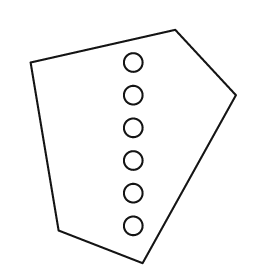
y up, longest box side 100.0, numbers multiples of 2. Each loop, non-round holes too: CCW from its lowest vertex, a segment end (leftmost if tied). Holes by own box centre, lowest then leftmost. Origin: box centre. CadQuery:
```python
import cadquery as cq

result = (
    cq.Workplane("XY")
    .moveTo(4.0, -50.0)
    .lineTo(44.0, 22.0)
    .lineTo(18.0, 50.0)
    .lineTo(-44.0, 36.0)
    .lineTo(-32.0, -36.0)
    .close()
    .moveTo(0.0, -34.0)
    .circle(4.0)
    .moveTo(0.0, -20.0)
    .circle(4.0)
    .moveTo(0.0, -6.0)
    .circle(4.0)
    .moveTo(0.0, 8.0)
    .circle(4.0)
    .moveTo(0.0, 22.0)
    .circle(4.0)
    .moveTo(0.0, 36.0)
    .circle(4.0)
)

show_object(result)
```